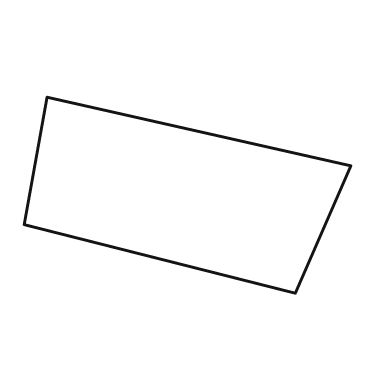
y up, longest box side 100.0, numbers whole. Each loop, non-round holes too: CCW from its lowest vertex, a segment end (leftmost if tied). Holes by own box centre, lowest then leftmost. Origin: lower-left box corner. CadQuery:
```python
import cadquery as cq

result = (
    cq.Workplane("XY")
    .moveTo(83.0, 0.0)
    .lineTo(100.0, 39.0)
    .lineTo(7.0, 60.0)
    .lineTo(0.0, 21.0)
    .close()
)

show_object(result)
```